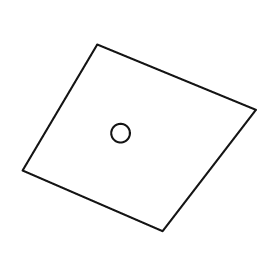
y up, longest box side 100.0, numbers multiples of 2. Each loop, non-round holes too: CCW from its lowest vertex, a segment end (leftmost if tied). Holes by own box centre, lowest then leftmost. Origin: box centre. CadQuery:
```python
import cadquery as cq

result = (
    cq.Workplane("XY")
    .moveTo(10.0, -40.0)
    .lineTo(50.0, 12.0)
    .lineTo(-18.0, 40.0)
    .lineTo(-50.0, -14.0)
    .close()
    .moveTo(-8.0, 2.0)
    .circle(4.0)
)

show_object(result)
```